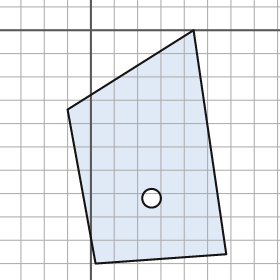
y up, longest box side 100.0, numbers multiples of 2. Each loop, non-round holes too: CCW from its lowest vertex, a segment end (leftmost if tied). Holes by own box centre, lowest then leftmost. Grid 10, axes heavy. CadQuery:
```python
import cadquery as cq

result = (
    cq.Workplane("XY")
    .moveTo(2.0, -100.0)
    .lineTo(58.0, -96.0)
    .lineTo(44.0, 0.0)
    .lineTo(-10.0, -34.0)
    .close()
    .moveTo(26.0, -72.0)
    .circle(4.0)
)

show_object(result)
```